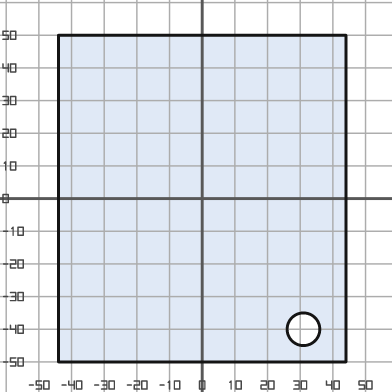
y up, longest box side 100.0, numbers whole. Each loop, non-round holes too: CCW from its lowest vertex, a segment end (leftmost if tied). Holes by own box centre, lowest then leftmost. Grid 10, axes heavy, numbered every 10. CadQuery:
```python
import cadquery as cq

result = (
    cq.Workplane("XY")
    .moveTo(-44.0, -50.0)
    .lineTo(44.0, -50.0)
    .lineTo(44.0, 50.0)
    .lineTo(-44.0, 50.0)
    .close()
    .moveTo(31.0, -40.0)
    .circle(5.0)
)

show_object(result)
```